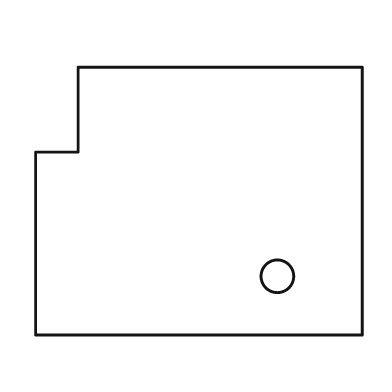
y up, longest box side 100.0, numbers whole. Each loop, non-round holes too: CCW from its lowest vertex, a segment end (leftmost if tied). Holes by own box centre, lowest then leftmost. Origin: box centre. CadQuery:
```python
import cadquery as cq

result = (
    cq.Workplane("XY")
    .moveTo(-50.0, -41.0)
    .lineTo(50.0, -41.0)
    .lineTo(50.0, 41.0)
    .lineTo(-37.0, 41.0)
    .lineTo(-37.0, 15.0)
    .lineTo(-50.0, 15.0)
    .close()
    .moveTo(24.0, -23.0)
    .circle(5.0)
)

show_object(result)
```